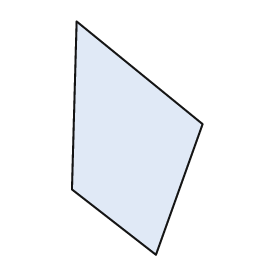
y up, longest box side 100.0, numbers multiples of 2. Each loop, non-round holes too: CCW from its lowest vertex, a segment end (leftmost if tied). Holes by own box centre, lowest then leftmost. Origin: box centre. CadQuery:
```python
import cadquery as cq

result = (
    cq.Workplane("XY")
    .moveTo(8.0, -50.0)
    .lineTo(28.0, 6.0)
    .lineTo(-26.0, 50.0)
    .lineTo(-28.0, -22.0)
    .close()
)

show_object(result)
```